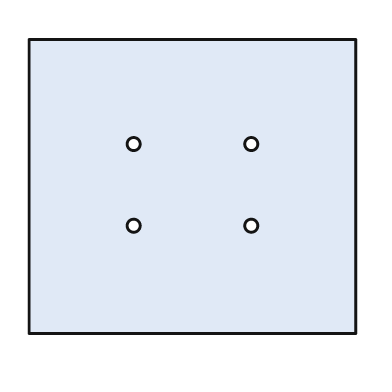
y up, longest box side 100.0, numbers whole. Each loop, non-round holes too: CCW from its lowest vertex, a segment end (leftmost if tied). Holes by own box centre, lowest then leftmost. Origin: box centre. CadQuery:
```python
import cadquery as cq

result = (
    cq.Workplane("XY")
    .moveTo(-50.0, -45.0)
    .lineTo(50.0, -45.0)
    .lineTo(50.0, 45.0)
    .lineTo(-50.0, 45.0)
    .close()
    .moveTo(-18.0, -12.0)
    .circle(2.0)
    .moveTo(18.0, -12.0)
    .circle(2.0)
    .moveTo(-18.0, 13.0)
    .circle(2.0)
    .moveTo(18.0, 13.0)
    .circle(2.0)
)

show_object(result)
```